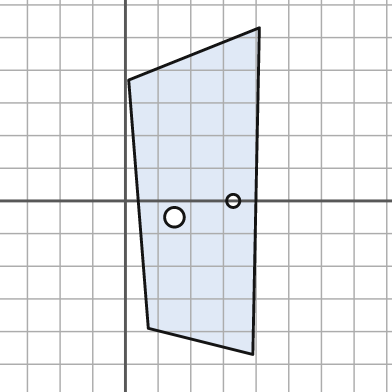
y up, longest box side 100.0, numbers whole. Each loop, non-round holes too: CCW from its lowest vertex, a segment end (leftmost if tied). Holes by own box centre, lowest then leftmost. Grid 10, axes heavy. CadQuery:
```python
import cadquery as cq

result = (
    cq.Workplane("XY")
    .moveTo(39.0, -47.0)
    .lineTo(41.0, 53.0)
    .lineTo(1.0, 37.0)
    .lineTo(7.0, -39.0)
    .close()
    .moveTo(15.0, -5.0)
    .circle(3.0)
    .moveTo(33.0, 0.0)
    .circle(2.0)
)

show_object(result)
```